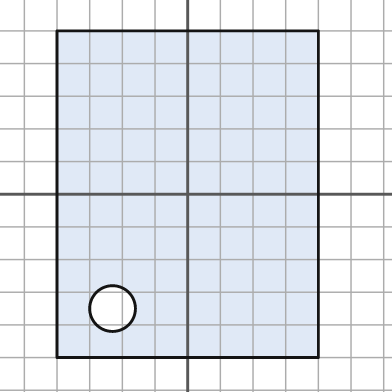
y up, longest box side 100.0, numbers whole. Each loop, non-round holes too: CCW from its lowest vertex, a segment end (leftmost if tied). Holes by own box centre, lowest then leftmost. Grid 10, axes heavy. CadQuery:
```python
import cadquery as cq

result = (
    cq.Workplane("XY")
    .moveTo(-40.0, -50.0)
    .lineTo(40.0, -50.0)
    .lineTo(40.0, 50.0)
    .lineTo(-40.0, 50.0)
    .close()
    .moveTo(-23.0, -35.0)
    .circle(7.0)
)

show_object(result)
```